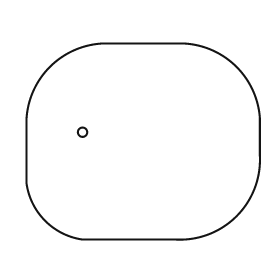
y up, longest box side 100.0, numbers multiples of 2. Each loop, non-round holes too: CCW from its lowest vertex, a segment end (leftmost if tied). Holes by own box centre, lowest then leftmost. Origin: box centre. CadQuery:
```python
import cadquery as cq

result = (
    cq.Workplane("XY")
    .moveTo(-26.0, -42.0)
    .lineTo(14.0, -42.0)
    .threePointArc((40.0, -32.0), (50.0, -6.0))
    .lineTo(50.0, 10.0)
    .threePointArc((40.0, 32.0), (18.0, 42.0))
    .lineTo(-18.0, 42.0)
    .threePointArc((-40.0, 32.0), (-50.0, 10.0))
    .lineTo(-50.0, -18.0)
    .threePointArc((-42.0, -34.0), (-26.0, -42.0))
    .close()
    .moveTo(-26.0, 4.0)
    .circle(2.0)
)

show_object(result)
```